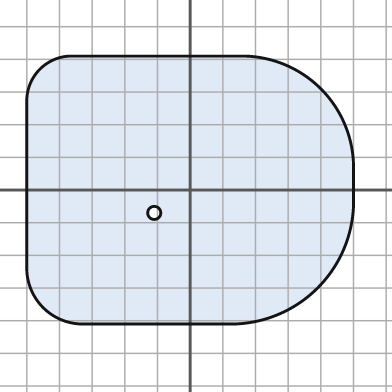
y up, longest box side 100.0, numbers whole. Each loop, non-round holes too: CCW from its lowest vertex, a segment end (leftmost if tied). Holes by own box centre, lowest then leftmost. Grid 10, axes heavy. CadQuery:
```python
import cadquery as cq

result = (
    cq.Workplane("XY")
    .moveTo(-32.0, -41.0)
    .lineTo(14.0, -41.0)
    .threePointArc((39.0, -30.0), (50.0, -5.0))
    .lineTo(50.0, 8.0)
    .threePointArc((40.0, 31.0), (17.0, 41.0))
    .lineTo(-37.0, 41.0)
    .threePointArc((-46.0, 37.0), (-50.0, 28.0))
    .lineTo(-50.0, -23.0)
    .threePointArc((-45.0, -36.0), (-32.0, -41.0))
    .close()
    .moveTo(-11.0, -7.0)
    .circle(2.0)
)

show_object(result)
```